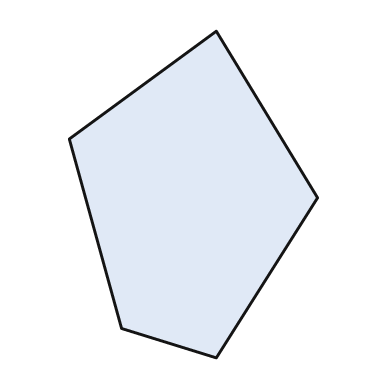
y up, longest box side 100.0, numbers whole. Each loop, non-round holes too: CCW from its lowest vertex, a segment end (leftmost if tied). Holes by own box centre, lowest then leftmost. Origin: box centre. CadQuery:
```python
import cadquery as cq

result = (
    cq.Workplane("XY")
    .moveTo(7.0, -50.0)
    .lineTo(38.0, -1.0)
    .lineTo(7.0, 50.0)
    .lineTo(-38.0, 17.0)
    .lineTo(-22.0, -41.0)
    .close()
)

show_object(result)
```